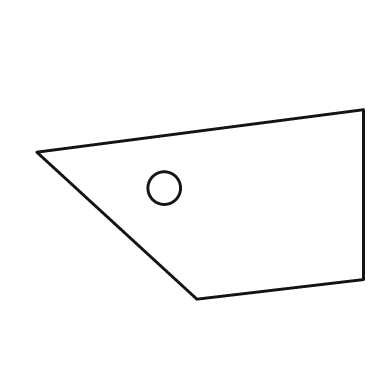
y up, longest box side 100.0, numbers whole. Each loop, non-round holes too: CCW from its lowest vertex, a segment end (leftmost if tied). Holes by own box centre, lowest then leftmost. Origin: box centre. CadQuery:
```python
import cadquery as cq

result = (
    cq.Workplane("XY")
    .moveTo(-1.0, -29.0)
    .lineTo(50.0, -23.0)
    .lineTo(50.0, 29.0)
    .lineTo(-50.0, 16.0)
    .close()
    .moveTo(-11.0, 5.0)
    .circle(5.0)
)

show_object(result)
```